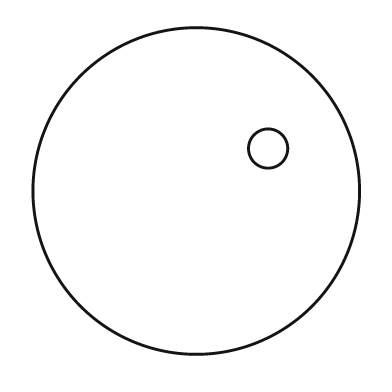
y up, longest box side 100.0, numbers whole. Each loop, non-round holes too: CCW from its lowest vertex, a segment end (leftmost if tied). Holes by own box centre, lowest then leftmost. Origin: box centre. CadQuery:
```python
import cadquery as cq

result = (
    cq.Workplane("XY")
    .moveTo(0.0, 0.0)
    .circle(50.0)
    .moveTo(22.0, 13.0)
    .circle(6.0)
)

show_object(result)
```